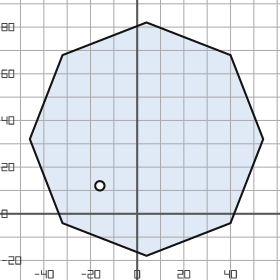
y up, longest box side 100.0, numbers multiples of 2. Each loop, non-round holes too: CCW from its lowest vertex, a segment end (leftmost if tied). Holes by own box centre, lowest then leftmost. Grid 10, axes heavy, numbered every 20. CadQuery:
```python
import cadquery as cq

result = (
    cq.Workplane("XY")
    .moveTo(4.0, -18.0)
    .lineTo(40.0, -4.0)
    .lineTo(54.0, 32.0)
    .lineTo(40.0, 68.0)
    .lineTo(4.0, 82.0)
    .lineTo(-32.0, 68.0)
    .lineTo(-46.0, 32.0)
    .lineTo(-32.0, -4.0)
    .close()
    .moveTo(-16.0, 12.0)
    .circle(2.0)
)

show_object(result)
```